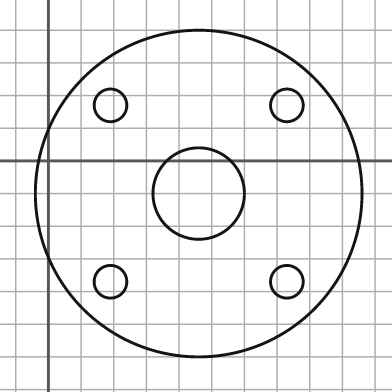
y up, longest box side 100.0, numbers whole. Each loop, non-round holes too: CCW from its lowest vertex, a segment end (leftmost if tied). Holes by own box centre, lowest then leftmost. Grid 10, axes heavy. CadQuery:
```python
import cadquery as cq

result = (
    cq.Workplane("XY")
    .moveTo(46.0, -10.0)
    .circle(50.0)
    .moveTo(19.0, -37.0)
    .circle(5.0)
    .moveTo(73.0, -37.0)
    .circle(5.0)
    .moveTo(46.0, -10.0)
    .circle(14.0)
    .moveTo(19.0, 17.0)
    .circle(5.0)
    .moveTo(73.0, 17.0)
    .circle(5.0)
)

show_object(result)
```